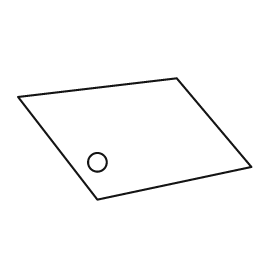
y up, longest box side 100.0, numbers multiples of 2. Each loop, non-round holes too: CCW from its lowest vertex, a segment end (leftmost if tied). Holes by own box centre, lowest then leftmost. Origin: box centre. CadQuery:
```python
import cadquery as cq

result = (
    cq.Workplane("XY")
    .moveTo(-16.0, -26.0)
    .lineTo(50.0, -12.0)
    .lineTo(18.0, 26.0)
    .lineTo(-50.0, 18.0)
    .close()
    .moveTo(-16.0, -10.0)
    .circle(4.0)
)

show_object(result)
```